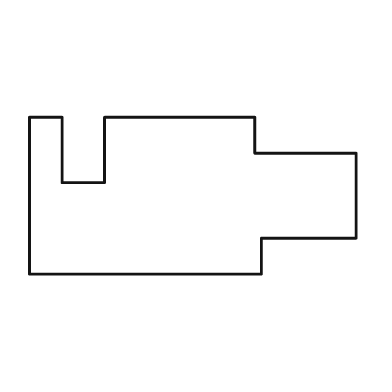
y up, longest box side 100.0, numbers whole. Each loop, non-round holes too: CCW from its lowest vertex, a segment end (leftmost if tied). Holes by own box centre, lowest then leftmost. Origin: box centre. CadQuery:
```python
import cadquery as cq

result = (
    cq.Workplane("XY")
    .moveTo(-50.0, -24.0)
    .lineTo(21.0, -24.0)
    .lineTo(21.0, -13.0)
    .lineTo(50.0, -13.0)
    .lineTo(50.0, 13.0)
    .lineTo(19.0, 13.0)
    .lineTo(19.0, 24.0)
    .lineTo(-27.0, 24.0)
    .lineTo(-27.0, 4.0)
    .lineTo(-40.0, 4.0)
    .lineTo(-40.0, 24.0)
    .lineTo(-50.0, 24.0)
    .close()
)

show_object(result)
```